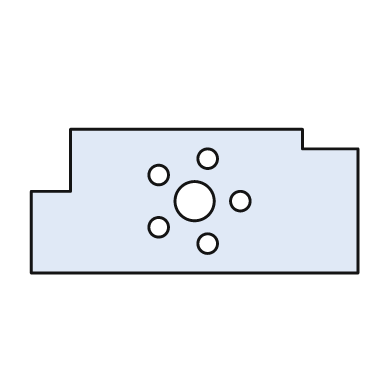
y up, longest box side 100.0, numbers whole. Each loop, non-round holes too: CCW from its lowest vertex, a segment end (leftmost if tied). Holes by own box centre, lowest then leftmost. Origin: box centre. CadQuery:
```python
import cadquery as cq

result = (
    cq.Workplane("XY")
    .moveTo(-50.0, -22.0)
    .lineTo(50.0, -22.0)
    .lineTo(50.0, 16.0)
    .lineTo(33.0, 16.0)
    .lineTo(33.0, 22.0)
    .lineTo(-38.0, 22.0)
    .lineTo(-38.0, 3.0)
    .lineTo(-50.0, 3.0)
    .close()
    .moveTo(4.0, -13.0)
    .circle(3.0)
    .moveTo(-11.0, -8.0)
    .circle(3.0)
    .moveTo(0.0, 0.0)
    .circle(6.0)
    .moveTo(14.0, 0.0)
    .circle(3.0)
    .moveTo(-11.0, 8.0)
    .circle(3.0)
    .moveTo(4.0, 13.0)
    .circle(3.0)
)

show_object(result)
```